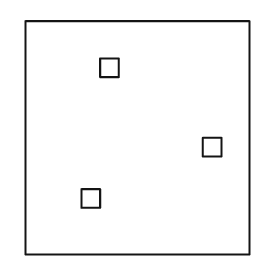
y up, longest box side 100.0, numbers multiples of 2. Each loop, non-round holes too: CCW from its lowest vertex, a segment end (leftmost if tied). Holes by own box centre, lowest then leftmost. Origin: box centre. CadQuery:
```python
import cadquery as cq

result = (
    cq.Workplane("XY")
    .moveTo(-48.0, -50.0)
    .lineTo(48.0, -50.0)
    .lineTo(48.0, 50.0)
    .lineTo(-48.0, 50.0)
    .close()
    .moveTo(-24.0, -30.0)
    .lineTo(-16.0, -30.0)
    .lineTo(-16.0, -22.0)
    .lineTo(-24.0, -22.0)
    .close()
    .moveTo(28.0, -8.0)
    .lineTo(36.0, -8.0)
    .lineTo(36.0, 0.0)
    .lineTo(28.0, 0.0)
    .close()
    .moveTo(-16.0, 26.0)
    .lineTo(-8.0, 26.0)
    .lineTo(-8.0, 34.0)
    .lineTo(-16.0, 34.0)
    .close()
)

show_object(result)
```